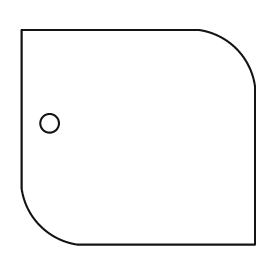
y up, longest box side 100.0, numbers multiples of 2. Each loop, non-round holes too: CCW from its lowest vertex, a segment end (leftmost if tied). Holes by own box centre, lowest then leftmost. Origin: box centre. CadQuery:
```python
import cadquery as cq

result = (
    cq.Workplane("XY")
    .moveTo(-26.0, -46.0)
    .lineTo(50.0, -46.0)
    .lineTo(50.0, 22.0)
    .threePointArc((42.0, 38.0), (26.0, 46.0))
    .lineTo(-50.0, 46.0)
    .lineTo(-50.0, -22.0)
    .threePointArc((-42.0, -38.0), (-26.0, -46.0))
    .close()
    .moveTo(-38.0, 6.0)
    .circle(4.0)
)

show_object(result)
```